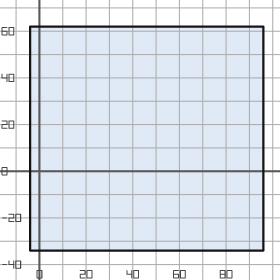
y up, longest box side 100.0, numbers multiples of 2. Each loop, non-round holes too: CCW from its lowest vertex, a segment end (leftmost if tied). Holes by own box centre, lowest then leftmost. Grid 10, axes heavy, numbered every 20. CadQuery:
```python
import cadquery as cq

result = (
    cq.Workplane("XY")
    .moveTo(-4.0, -34.0)
    .lineTo(96.0, -34.0)
    .lineTo(96.0, 62.0)
    .lineTo(-4.0, 62.0)
    .close()
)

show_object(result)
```